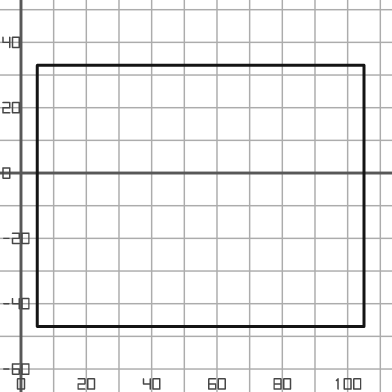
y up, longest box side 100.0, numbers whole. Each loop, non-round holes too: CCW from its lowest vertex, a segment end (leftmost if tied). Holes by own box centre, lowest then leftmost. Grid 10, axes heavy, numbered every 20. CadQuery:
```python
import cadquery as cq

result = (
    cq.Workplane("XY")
    .moveTo(5.0, -47.0)
    .lineTo(105.0, -47.0)
    .lineTo(105.0, 33.0)
    .lineTo(5.0, 33.0)
    .close()
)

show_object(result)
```